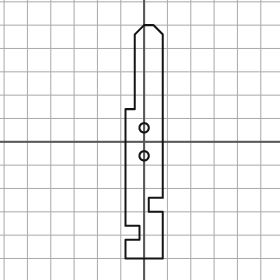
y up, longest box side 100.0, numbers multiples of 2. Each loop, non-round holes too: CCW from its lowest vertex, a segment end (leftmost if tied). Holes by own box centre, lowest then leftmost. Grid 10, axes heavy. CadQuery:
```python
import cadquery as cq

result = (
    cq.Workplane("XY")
    .moveTo(-8.0, -50.0)
    .lineTo(8.0, -50.0)
    .lineTo(8.0, -30.0)
    .lineTo(2.0, -30.0)
    .lineTo(2.0, -24.0)
    .lineTo(8.0, -24.0)
    .lineTo(8.0, 46.0)
    .lineTo(4.0, 50.0)
    .lineTo(0.0, 50.0)
    .lineTo(-4.0, 46.0)
    .lineTo(-4.0, 14.0)
    .lineTo(-8.0, 14.0)
    .lineTo(-8.0, -36.0)
    .lineTo(-2.0, -36.0)
    .lineTo(-2.0, -42.0)
    .lineTo(-8.0, -42.0)
    .close()
    .moveTo(0.0, -6.0)
    .circle(2.0)
    .moveTo(0.0, 6.0)
    .circle(2.0)
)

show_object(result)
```